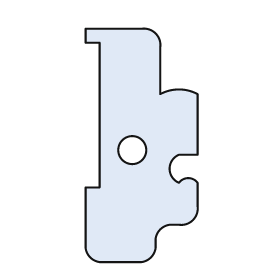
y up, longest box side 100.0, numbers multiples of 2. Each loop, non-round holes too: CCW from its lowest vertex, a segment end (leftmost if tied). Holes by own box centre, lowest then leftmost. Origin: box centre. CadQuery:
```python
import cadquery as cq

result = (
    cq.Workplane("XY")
    .moveTo(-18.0, -50.0)
    .lineTo(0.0, -50.0)
    .threePointArc((4.0, -48.0), (6.0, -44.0))
    .lineTo(6.0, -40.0)
    .threePointArc((8.0, -36.0), (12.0, -34.0))
    .lineTo(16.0, -34.0)
    .threePointArc((22.0, -32.0), (24.0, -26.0))
    .lineTo(24.0, -16.0)
    .threePointArc((20.0, -14.0), (16.0, -16.0))
    .threePointArc((12.0, -10.0), (16.0, -4.0))
    .lineTo(24.0, -4.0)
    .lineTo(24.0, 22.0)
    .threePointArc((16.0, 24.0), (8.0, 22.0))
    .lineTo(8.0, 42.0)
    .threePointArc((6.0, 48.0), (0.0, 50.0))
    .lineTo(-24.0, 50.0)
    .lineTo(-24.0, 44.0)
    .lineTo(-18.0, 44.0)
    .lineTo(-18.0, -18.0)
    .lineTo(-24.0, -18.0)
    .lineTo(-24.0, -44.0)
    .threePointArc((-22.0, -48.0), (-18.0, -50.0))
    .close()
    .moveTo(-4.0, -2.0)
    .circle(6.0)
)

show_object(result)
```